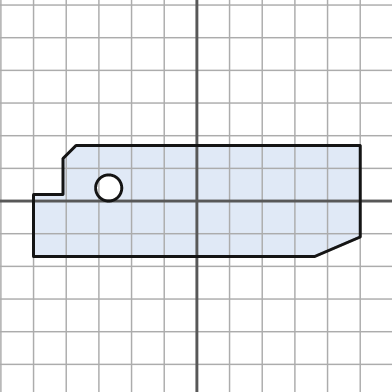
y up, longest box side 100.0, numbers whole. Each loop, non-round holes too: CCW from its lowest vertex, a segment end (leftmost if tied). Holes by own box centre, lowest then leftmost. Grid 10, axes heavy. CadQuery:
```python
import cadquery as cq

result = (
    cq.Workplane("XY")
    .moveTo(-50.0, -17.0)
    .lineTo(36.0, -17.0)
    .lineTo(50.0, -11.0)
    .lineTo(50.0, 17.0)
    .lineTo(-37.0, 17.0)
    .lineTo(-41.0, 13.0)
    .lineTo(-41.0, 2.0)
    .lineTo(-50.0, 2.0)
    .close()
    .moveTo(-27.0, 4.0)
    .circle(4.0)
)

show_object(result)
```